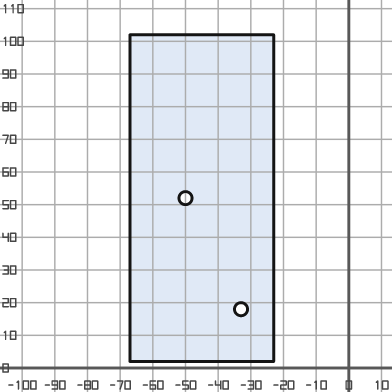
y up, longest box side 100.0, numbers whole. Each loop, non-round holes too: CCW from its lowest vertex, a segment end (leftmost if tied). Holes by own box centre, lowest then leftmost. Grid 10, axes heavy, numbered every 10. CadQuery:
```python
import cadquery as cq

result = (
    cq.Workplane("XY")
    .moveTo(-67.0, 2.0)
    .lineTo(-23.0, 2.0)
    .lineTo(-23.0, 102.0)
    .lineTo(-67.0, 102.0)
    .close()
    .moveTo(-33.0, 18.0)
    .circle(2.0)
    .moveTo(-50.0, 52.0)
    .circle(2.0)
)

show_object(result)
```